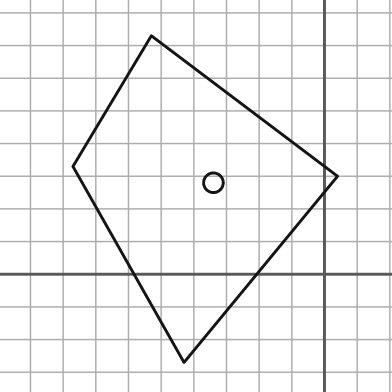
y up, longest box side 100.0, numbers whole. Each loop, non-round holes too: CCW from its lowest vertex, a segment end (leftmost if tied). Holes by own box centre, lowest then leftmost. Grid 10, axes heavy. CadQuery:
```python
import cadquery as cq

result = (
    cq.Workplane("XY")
    .moveTo(-43.0, -27.0)
    .lineTo(4.0, 30.0)
    .lineTo(-53.0, 73.0)
    .lineTo(-77.0, 33.0)
    .close()
    .moveTo(-34.0, 28.0)
    .circle(3.0)
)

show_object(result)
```